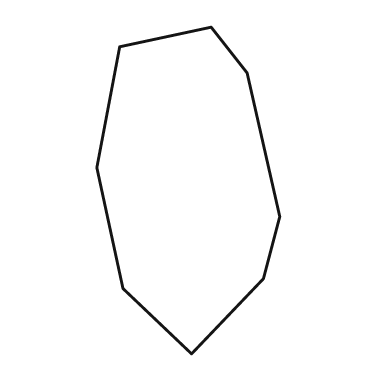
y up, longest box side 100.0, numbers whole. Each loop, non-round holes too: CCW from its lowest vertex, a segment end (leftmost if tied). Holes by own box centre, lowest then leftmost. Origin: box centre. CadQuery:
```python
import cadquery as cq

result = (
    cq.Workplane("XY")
    .moveTo(1.0, -50.0)
    .lineTo(23.0, -27.0)
    .lineTo(28.0, -8.0)
    .lineTo(18.0, 36.0)
    .lineTo(7.0, 50.0)
    .lineTo(-21.0, 44.0)
    .lineTo(-28.0, 7.0)
    .lineTo(-20.0, -30.0)
    .close()
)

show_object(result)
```